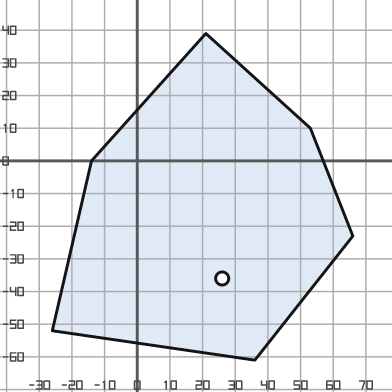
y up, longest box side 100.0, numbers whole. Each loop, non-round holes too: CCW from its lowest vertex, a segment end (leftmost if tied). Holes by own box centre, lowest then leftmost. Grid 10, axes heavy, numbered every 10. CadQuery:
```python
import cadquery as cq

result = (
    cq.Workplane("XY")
    .moveTo(36.0, -61.0)
    .lineTo(66.0, -23.0)
    .lineTo(53.0, 10.0)
    .lineTo(21.0, 39.0)
    .lineTo(-14.0, 0.0)
    .lineTo(-26.0, -52.0)
    .close()
    .moveTo(26.0, -36.0)
    .circle(2.0)
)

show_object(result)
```